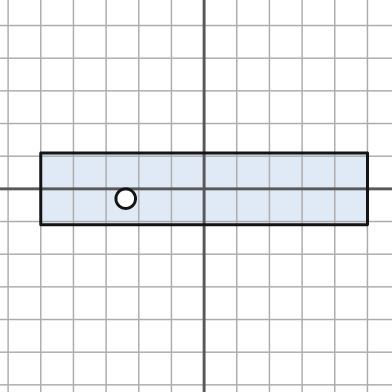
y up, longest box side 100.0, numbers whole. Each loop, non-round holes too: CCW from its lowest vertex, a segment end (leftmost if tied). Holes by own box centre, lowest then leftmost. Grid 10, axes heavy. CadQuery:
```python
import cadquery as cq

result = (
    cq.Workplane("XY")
    .moveTo(-50.0, -11.0)
    .lineTo(50.0, -11.0)
    .lineTo(50.0, 11.0)
    .lineTo(-50.0, 11.0)
    .close()
    .moveTo(-24.0, -3.0)
    .circle(3.0)
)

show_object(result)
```